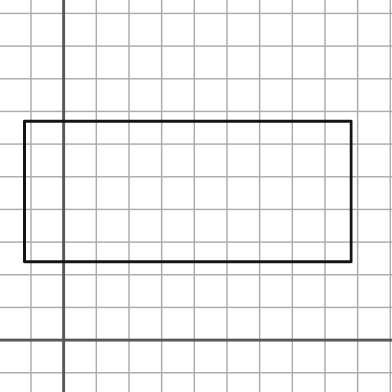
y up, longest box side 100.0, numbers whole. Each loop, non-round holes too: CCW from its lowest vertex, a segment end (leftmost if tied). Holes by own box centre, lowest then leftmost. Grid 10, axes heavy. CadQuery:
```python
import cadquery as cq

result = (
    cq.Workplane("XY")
    .moveTo(-12.0, 24.0)
    .lineTo(88.0, 24.0)
    .lineTo(88.0, 67.0)
    .lineTo(-12.0, 67.0)
    .close()
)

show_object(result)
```